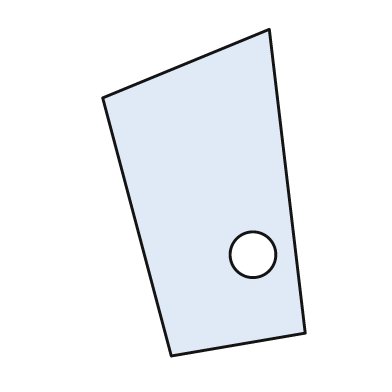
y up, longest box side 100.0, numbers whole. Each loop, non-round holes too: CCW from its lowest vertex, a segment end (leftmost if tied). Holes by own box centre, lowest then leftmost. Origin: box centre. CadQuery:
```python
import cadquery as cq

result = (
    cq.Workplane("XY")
    .moveTo(-10.0, -50.0)
    .lineTo(31.0, -43.0)
    .lineTo(20.0, 50.0)
    .lineTo(-31.0, 29.0)
    .close()
    .moveTo(15.0, -19.0)
    .circle(7.0)
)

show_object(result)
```